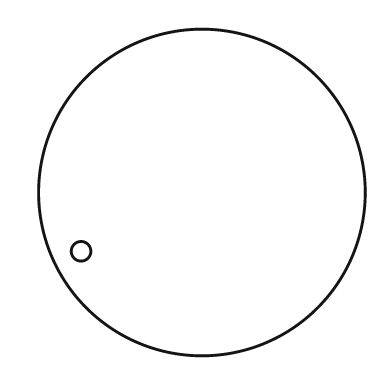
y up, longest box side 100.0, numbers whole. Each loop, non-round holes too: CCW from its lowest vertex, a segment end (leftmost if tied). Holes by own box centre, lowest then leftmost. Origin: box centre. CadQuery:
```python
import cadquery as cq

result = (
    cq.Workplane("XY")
    .moveTo(0.0, 0.0)
    .circle(50.0)
    .moveTo(-37.0, -18.0)
    .circle(3.0)
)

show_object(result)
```